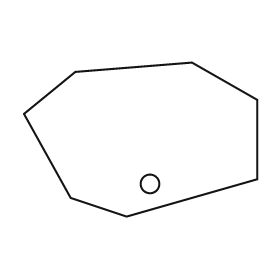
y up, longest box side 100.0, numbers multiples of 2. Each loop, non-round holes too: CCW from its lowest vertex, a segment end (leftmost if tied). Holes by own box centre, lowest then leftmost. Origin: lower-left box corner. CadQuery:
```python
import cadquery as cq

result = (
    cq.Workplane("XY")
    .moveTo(44.0, 0.0)
    .lineTo(100.0, 16.0)
    .lineTo(100.0, 50.0)
    .lineTo(72.0, 66.0)
    .lineTo(22.0, 62.0)
    .lineTo(0.0, 44.0)
    .lineTo(20.0, 8.0)
    .close()
    .moveTo(54.0, 14.0)
    .circle(4.0)
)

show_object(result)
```